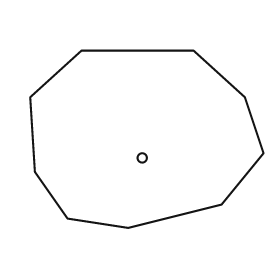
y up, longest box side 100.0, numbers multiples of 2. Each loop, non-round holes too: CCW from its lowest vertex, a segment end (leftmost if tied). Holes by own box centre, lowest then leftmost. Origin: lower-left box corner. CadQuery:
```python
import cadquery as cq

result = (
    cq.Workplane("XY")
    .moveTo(42.0, 0.0)
    .lineTo(82.0, 10.0)
    .lineTo(100.0, 32.0)
    .lineTo(92.0, 56.0)
    .lineTo(70.0, 76.0)
    .lineTo(22.0, 76.0)
    .lineTo(0.0, 56.0)
    .lineTo(2.0, 24.0)
    .lineTo(16.0, 4.0)
    .close()
    .moveTo(48.0, 30.0)
    .circle(2.0)
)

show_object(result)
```